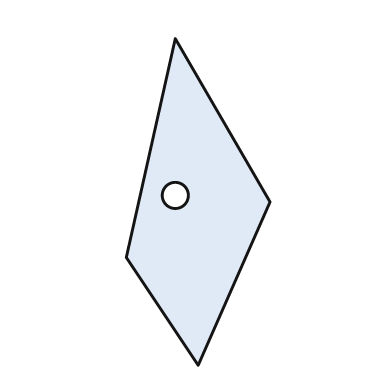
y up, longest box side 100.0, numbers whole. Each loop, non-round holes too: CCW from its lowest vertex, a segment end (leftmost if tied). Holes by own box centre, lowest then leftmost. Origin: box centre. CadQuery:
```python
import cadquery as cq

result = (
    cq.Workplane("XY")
    .moveTo(0.0, -50.0)
    .lineTo(22.0, 0.0)
    .lineTo(-7.0, 50.0)
    .lineTo(-22.0, -17.0)
    .close()
    .moveTo(-7.0, 2.0)
    .circle(4.0)
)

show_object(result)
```